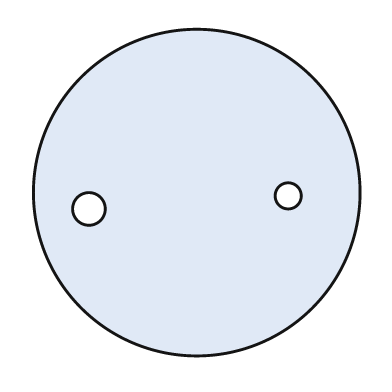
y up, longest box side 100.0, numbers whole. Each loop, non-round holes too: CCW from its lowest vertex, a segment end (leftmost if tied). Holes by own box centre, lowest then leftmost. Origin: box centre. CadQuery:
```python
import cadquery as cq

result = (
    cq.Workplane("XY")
    .moveTo(0.0, 0.0)
    .circle(50.0)
    .moveTo(-33.0, -5.0)
    .circle(5.0)
    .moveTo(28.0, -1.0)
    .circle(4.0)
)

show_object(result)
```